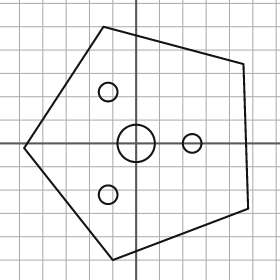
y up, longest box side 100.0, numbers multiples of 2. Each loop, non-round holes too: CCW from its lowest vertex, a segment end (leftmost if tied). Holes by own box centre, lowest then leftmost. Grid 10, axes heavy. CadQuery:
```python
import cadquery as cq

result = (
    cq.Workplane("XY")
    .moveTo(-10.0, -50.0)
    .lineTo(48.0, -28.0)
    .lineTo(46.0, 34.0)
    .lineTo(-14.0, 50.0)
    .lineTo(-48.0, -2.0)
    .close()
    .moveTo(-12.0, -22.0)
    .circle(4.0)
    .moveTo(0.0, 0.0)
    .circle(8.0)
    .moveTo(24.0, 0.0)
    .circle(4.0)
    .moveTo(-12.0, 22.0)
    .circle(4.0)
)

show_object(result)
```